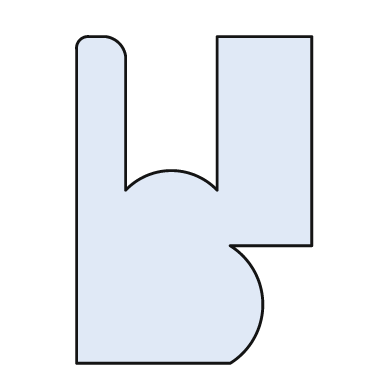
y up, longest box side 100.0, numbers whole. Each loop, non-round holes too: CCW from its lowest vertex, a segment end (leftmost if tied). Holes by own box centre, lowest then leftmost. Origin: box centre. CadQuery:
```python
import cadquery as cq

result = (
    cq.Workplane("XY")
    .moveTo(-36.0, -50.0)
    .lineTo(11.0, -50.0)
    .threePointArc((21.0, -32.0), (11.0, -14.0))
    .lineTo(36.0, -14.0)
    .lineTo(36.0, 50.0)
    .lineTo(7.0, 50.0)
    .lineTo(7.0, 3.0)
    .threePointArc((-7.0, 9.0), (-21.0, 3.0))
    .lineTo(-21.0, 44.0)
    .threePointArc((-23.0, 48.0), (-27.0, 50.0))
    .lineTo(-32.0, 50.0)
    .threePointArc((-35.0, 49.0), (-36.0, 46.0))
    .close()
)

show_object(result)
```